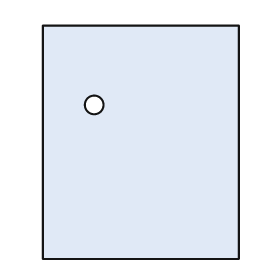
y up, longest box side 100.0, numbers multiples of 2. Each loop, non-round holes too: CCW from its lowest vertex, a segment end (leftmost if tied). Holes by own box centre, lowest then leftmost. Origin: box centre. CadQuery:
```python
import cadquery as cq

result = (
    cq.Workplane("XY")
    .moveTo(-42.0, -50.0)
    .lineTo(42.0, -50.0)
    .lineTo(42.0, 50.0)
    .lineTo(-42.0, 50.0)
    .close()
    .moveTo(-20.0, 16.0)
    .circle(4.0)
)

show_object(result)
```